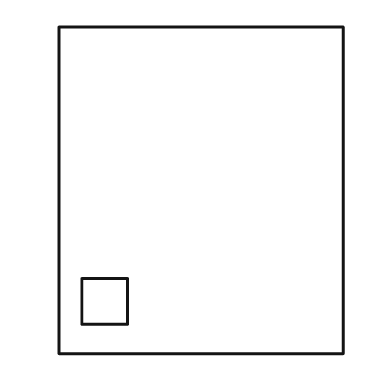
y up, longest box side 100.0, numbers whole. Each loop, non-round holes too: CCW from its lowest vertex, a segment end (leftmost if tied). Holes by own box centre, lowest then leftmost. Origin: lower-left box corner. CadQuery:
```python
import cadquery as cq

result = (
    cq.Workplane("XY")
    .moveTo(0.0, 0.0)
    .lineTo(87.0, 0.0)
    .lineTo(87.0, 100.0)
    .lineTo(0.0, 100.0)
    .close()
    .moveTo(7.0, 9.0)
    .lineTo(21.0, 9.0)
    .lineTo(21.0, 23.0)
    .lineTo(7.0, 23.0)
    .close()
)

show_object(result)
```